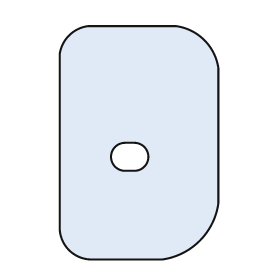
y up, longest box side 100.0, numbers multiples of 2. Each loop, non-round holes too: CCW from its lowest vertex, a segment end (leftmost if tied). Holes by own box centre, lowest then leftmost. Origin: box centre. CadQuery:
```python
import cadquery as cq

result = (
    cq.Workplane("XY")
    .moveTo(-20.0, -50.0)
    .lineTo(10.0, -50.0)
    .threePointArc((26.0, -42.0), (34.0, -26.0))
    .lineTo(34.0, 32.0)
    .threePointArc((28.0, 44.0), (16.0, 50.0))
    .lineTo(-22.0, 50.0)
    .threePointArc((-30.0, 46.0), (-34.0, 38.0))
    .lineTo(-34.0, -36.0)
    .threePointArc((-30.0, -46.0), (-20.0, -50.0))
    .close()
    .moveTo(-6.0, -12.0)
    .lineTo(-2.0, -12.0)
    .threePointArc((4.0, -6.0), (-2.0, 0.0))
    .lineTo(-6.0, 0.0)
    .threePointArc((-12.0, -6.0), (-6.0, -12.0))
    .close()
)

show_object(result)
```